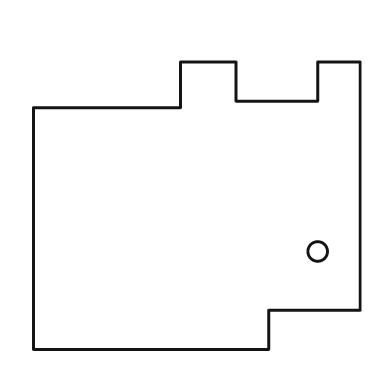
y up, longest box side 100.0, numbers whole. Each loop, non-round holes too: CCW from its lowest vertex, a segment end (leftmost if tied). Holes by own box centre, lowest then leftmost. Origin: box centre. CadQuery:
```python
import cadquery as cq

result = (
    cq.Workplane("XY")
    .moveTo(-50.0, -44.0)
    .lineTo(22.0, -44.0)
    .lineTo(22.0, -32.0)
    .lineTo(50.0, -32.0)
    .lineTo(50.0, 44.0)
    .lineTo(37.0, 44.0)
    .lineTo(37.0, 32.0)
    .lineTo(12.0, 32.0)
    .lineTo(12.0, 44.0)
    .lineTo(-5.0, 44.0)
    .lineTo(-5.0, 30.0)
    .lineTo(-50.0, 30.0)
    .close()
    .moveTo(37.0, -14.0)
    .circle(3.0)
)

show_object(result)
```